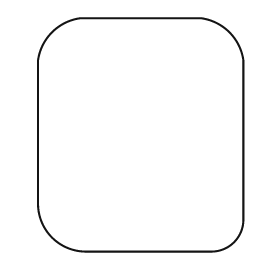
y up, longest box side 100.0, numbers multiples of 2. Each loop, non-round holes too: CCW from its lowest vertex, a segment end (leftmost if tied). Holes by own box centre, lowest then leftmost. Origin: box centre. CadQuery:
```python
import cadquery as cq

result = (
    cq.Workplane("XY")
    .moveTo(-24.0, -50.0)
    .lineTo(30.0, -50.0)
    .threePointArc((40.0, -46.0), (44.0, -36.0))
    .lineTo(44.0, 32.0)
    .threePointArc((38.0, 44.0), (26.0, 50.0))
    .lineTo(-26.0, 50.0)
    .threePointArc((-38.0, 44.0), (-44.0, 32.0))
    .lineTo(-44.0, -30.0)
    .threePointArc((-38.0, -44.0), (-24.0, -50.0))
    .close()
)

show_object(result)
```